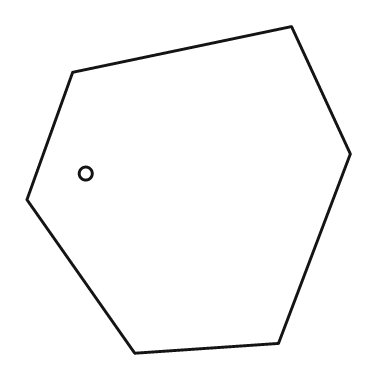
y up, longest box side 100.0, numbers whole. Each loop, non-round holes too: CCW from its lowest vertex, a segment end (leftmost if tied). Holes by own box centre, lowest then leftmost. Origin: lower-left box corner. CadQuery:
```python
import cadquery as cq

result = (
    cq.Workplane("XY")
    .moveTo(33.0, 0.0)
    .lineTo(77.0, 3.0)
    .lineTo(99.0, 61.0)
    .lineTo(81.0, 100.0)
    .lineTo(14.0, 86.0)
    .lineTo(0.0, 47.0)
    .close()
    .moveTo(18.0, 55.0)
    .circle(2.0)
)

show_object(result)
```